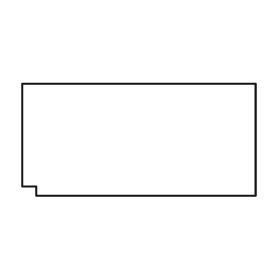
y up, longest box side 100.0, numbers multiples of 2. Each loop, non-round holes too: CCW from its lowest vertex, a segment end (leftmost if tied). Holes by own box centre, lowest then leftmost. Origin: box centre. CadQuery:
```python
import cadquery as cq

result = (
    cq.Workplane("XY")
    .moveTo(-44.0, -24.0)
    .lineTo(50.0, -24.0)
    .lineTo(50.0, 24.0)
    .lineTo(-50.0, 24.0)
    .lineTo(-50.0, -20.0)
    .lineTo(-44.0, -20.0)
    .close()
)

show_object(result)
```